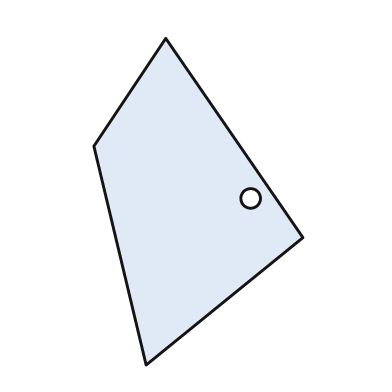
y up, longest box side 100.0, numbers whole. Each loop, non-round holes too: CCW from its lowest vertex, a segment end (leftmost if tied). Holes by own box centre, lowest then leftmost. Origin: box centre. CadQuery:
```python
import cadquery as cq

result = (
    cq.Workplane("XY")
    .moveTo(-16.0, -50.0)
    .lineTo(32.0, -11.0)
    .lineTo(-10.0, 50.0)
    .lineTo(-32.0, 17.0)
    .close()
    .moveTo(16.0, 1.0)
    .circle(3.0)
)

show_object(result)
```